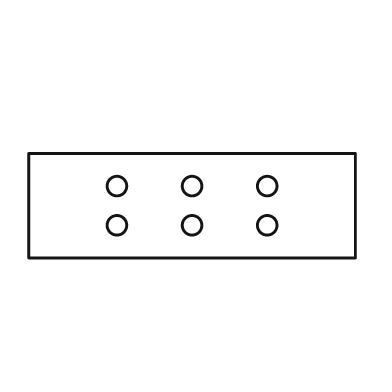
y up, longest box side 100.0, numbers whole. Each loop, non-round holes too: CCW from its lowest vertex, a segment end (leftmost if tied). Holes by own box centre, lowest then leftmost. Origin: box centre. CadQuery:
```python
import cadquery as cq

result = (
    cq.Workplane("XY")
    .moveTo(-50.0, -16.0)
    .lineTo(50.0, -16.0)
    .lineTo(50.0, 16.0)
    .lineTo(-50.0, 16.0)
    .close()
    .moveTo(-23.0, -6.0)
    .circle(3.0)
    .moveTo(0.0, -6.0)
    .circle(3.0)
    .moveTo(23.0, -6.0)
    .circle(3.0)
    .moveTo(-23.0, 6.0)
    .circle(3.0)
    .moveTo(0.0, 6.0)
    .circle(3.0)
    .moveTo(23.0, 6.0)
    .circle(3.0)
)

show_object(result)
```